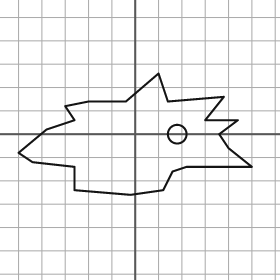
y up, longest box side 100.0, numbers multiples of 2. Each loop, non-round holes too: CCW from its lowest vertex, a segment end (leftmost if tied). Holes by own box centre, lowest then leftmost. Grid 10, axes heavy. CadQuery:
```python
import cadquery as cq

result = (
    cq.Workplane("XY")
    .moveTo(-2.0, -26.0)
    .lineTo(12.0, -24.0)
    .lineTo(16.0, -16.0)
    .lineTo(22.0, -14.0)
    .lineTo(50.0, -14.0)
    .lineTo(40.0, -6.0)
    .lineTo(36.0, 0.0)
    .lineTo(44.0, 6.0)
    .lineTo(30.0, 6.0)
    .lineTo(38.0, 16.0)
    .lineTo(14.0, 14.0)
    .lineTo(10.0, 26.0)
    .lineTo(-4.0, 14.0)
    .lineTo(-20.0, 14.0)
    .lineTo(-30.0, 12.0)
    .lineTo(-26.0, 6.0)
    .lineTo(-38.0, 2.0)
    .lineTo(-50.0, -8.0)
    .lineTo(-44.0, -12.0)
    .lineTo(-26.0, -14.0)
    .lineTo(-26.0, -24.0)
    .close()
    .moveTo(18.0, 0.0)
    .circle(4.0)
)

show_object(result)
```